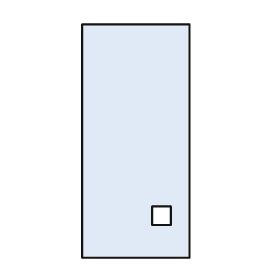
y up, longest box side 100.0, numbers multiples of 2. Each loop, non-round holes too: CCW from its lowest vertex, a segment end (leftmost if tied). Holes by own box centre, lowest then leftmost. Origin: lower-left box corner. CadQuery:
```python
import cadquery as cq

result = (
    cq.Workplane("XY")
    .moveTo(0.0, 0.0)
    .lineTo(46.0, 0.0)
    .lineTo(46.0, 100.0)
    .lineTo(0.0, 100.0)
    .close()
    .moveTo(30.0, 14.0)
    .lineTo(38.0, 14.0)
    .lineTo(38.0, 22.0)
    .lineTo(30.0, 22.0)
    .close()
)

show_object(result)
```